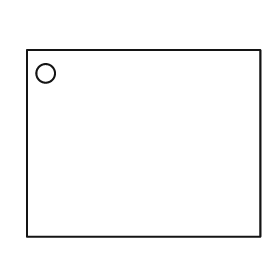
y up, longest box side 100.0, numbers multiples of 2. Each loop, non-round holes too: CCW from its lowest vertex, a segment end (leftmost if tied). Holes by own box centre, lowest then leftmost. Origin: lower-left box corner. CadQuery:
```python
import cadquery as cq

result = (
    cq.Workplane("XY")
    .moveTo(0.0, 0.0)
    .lineTo(100.0, 0.0)
    .lineTo(100.0, 80.0)
    .lineTo(0.0, 80.0)
    .close()
    .moveTo(8.0, 70.0)
    .circle(4.0)
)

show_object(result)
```